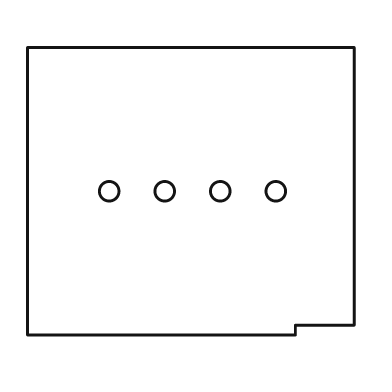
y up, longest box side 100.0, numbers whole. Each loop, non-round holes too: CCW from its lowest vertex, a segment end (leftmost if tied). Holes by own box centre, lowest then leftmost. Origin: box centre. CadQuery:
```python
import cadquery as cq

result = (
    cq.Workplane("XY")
    .moveTo(-50.0, -44.0)
    .lineTo(32.0, -44.0)
    .lineTo(32.0, -41.0)
    .lineTo(50.0, -41.0)
    .lineTo(50.0, 44.0)
    .lineTo(-50.0, 44.0)
    .close()
    .moveTo(-25.0, 0.0)
    .circle(3.0)
    .moveTo(-8.0, 0.0)
    .circle(3.0)
    .moveTo(9.0, 0.0)
    .circle(3.0)
    .moveTo(26.0, 0.0)
    .circle(3.0)
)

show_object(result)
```